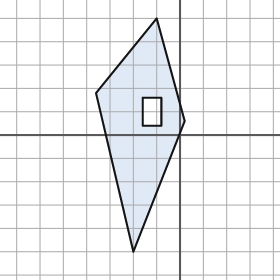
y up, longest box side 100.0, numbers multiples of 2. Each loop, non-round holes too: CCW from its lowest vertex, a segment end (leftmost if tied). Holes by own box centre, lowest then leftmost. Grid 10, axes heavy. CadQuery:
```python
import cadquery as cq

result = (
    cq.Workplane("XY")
    .moveTo(-20.0, -50.0)
    .lineTo(2.0, 6.0)
    .lineTo(-10.0, 50.0)
    .lineTo(-36.0, 18.0)
    .close()
    .moveTo(-16.0, 4.0)
    .lineTo(-8.0, 4.0)
    .lineTo(-8.0, 16.0)
    .lineTo(-16.0, 16.0)
    .close()
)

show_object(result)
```